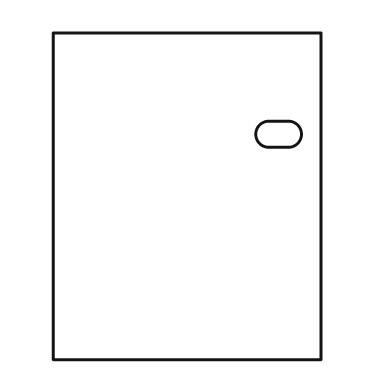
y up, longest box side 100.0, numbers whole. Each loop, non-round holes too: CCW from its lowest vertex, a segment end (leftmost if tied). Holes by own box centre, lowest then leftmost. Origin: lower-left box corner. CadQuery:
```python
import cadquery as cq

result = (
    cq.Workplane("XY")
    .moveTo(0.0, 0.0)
    .lineTo(82.0, 0.0)
    .lineTo(82.0, 100.0)
    .lineTo(0.0, 100.0)
    .close()
    .moveTo(66.0, 65.0)
    .lineTo(72.0, 65.0)
    .threePointArc((76.0, 69.0), (72.0, 73.0))
    .lineTo(66.0, 73.0)
    .threePointArc((62.0, 69.0), (66.0, 65.0))
    .close()
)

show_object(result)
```